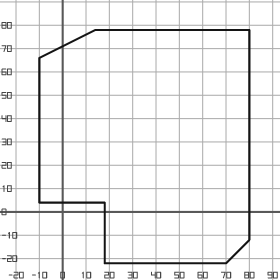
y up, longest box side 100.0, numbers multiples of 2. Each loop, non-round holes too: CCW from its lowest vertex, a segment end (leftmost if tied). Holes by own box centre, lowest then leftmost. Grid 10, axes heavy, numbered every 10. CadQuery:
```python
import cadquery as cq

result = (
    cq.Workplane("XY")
    .moveTo(18.0, -22.0)
    .lineTo(70.0, -22.0)
    .lineTo(80.0, -12.0)
    .lineTo(80.0, 78.0)
    .lineTo(14.0, 78.0)
    .lineTo(-10.0, 66.0)
    .lineTo(-10.0, 4.0)
    .lineTo(18.0, 4.0)
    .close()
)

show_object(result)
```